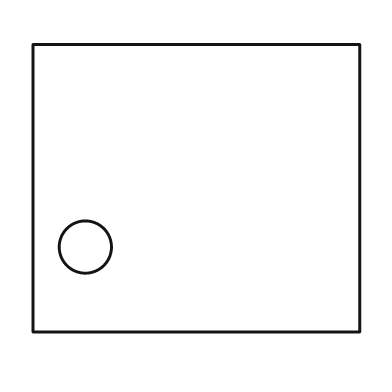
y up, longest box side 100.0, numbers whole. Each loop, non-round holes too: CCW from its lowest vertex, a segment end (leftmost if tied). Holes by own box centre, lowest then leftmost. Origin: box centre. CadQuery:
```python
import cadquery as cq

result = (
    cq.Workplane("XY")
    .moveTo(-50.0, -44.0)
    .lineTo(50.0, -44.0)
    .lineTo(50.0, 44.0)
    .lineTo(-50.0, 44.0)
    .close()
    .moveTo(-34.0, -18.0)
    .circle(8.0)
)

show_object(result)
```